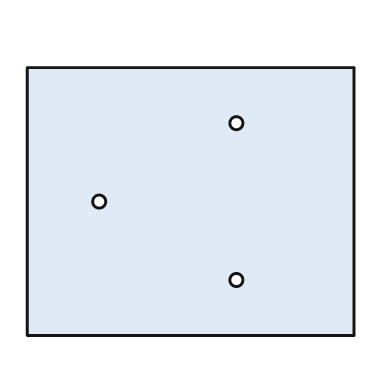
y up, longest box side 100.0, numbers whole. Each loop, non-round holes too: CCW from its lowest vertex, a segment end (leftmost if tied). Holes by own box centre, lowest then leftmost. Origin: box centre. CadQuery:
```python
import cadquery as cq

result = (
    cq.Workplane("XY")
    .moveTo(-50.0, -41.0)
    .lineTo(50.0, -41.0)
    .lineTo(50.0, 41.0)
    .lineTo(-50.0, 41.0)
    .close()
    .moveTo(14.0, -24.0)
    .circle(2.0)
    .moveTo(-28.0, 0.0)
    .circle(2.0)
    .moveTo(14.0, 24.0)
    .circle(2.0)
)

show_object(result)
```